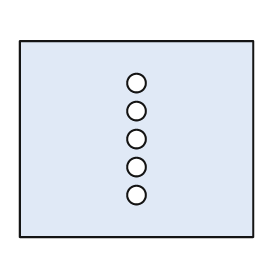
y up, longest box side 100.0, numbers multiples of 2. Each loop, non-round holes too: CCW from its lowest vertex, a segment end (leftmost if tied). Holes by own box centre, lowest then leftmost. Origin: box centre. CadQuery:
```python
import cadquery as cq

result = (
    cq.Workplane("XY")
    .moveTo(-50.0, -42.0)
    .lineTo(50.0, -42.0)
    .lineTo(50.0, 42.0)
    .lineTo(-50.0, 42.0)
    .close()
    .moveTo(0.0, -24.0)
    .circle(4.0)
    .moveTo(0.0, -12.0)
    .circle(4.0)
    .moveTo(0.0, 0.0)
    .circle(4.0)
    .moveTo(0.0, 12.0)
    .circle(4.0)
    .moveTo(0.0, 24.0)
    .circle(4.0)
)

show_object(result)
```